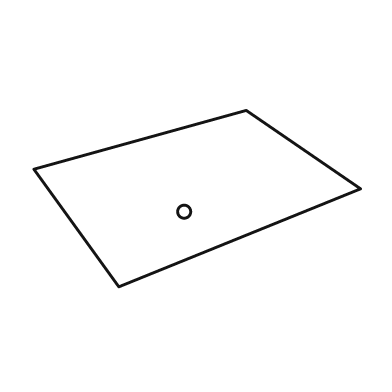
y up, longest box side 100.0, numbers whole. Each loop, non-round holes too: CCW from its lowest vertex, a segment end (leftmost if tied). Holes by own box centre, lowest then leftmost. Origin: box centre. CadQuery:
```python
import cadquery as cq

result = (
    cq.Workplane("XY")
    .moveTo(-24.0, -27.0)
    .lineTo(50.0, 3.0)
    .lineTo(15.0, 27.0)
    .lineTo(-50.0, 9.0)
    .close()
    .moveTo(-4.0, -4.0)
    .circle(2.0)
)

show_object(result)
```